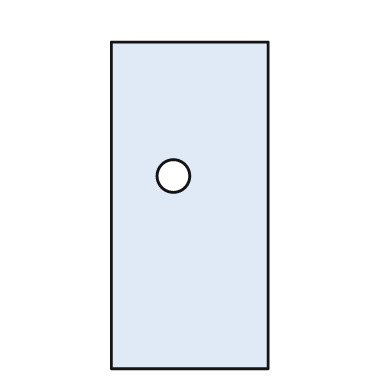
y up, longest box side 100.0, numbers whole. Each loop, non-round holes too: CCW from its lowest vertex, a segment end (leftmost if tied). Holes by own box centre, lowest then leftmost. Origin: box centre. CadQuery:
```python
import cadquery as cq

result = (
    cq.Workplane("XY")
    .moveTo(-24.0, -50.0)
    .lineTo(24.0, -50.0)
    .lineTo(24.0, 50.0)
    .lineTo(-24.0, 50.0)
    .close()
    .moveTo(-5.0, 9.0)
    .circle(5.0)
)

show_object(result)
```